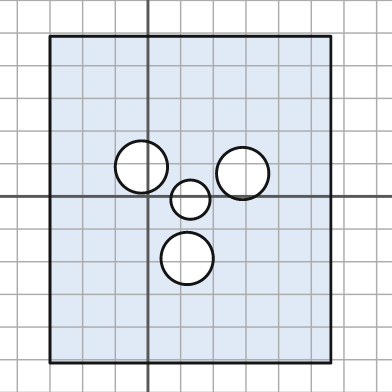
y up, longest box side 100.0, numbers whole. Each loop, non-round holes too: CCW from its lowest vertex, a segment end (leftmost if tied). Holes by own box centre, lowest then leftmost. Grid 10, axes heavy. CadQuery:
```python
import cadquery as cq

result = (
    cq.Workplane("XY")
    .moveTo(-30.0, -51.0)
    .lineTo(56.0, -51.0)
    .lineTo(56.0, 49.0)
    .lineTo(-30.0, 49.0)
    .close()
    .moveTo(12.0, -19.0)
    .circle(8.0)
    .moveTo(13.0, -1.0)
    .circle(6.0)
    .moveTo(29.0, 7.0)
    .circle(8.0)
    .moveTo(-2.0, 9.0)
    .circle(8.0)
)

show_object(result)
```